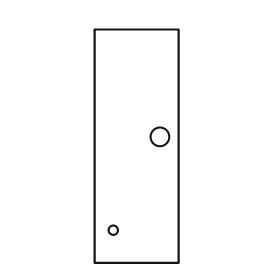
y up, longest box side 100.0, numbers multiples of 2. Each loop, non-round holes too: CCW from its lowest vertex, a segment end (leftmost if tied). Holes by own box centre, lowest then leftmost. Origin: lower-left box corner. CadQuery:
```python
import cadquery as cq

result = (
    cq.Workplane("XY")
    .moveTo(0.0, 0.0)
    .lineTo(36.0, 0.0)
    .lineTo(36.0, 100.0)
    .lineTo(0.0, 100.0)
    .close()
    .moveTo(8.0, 14.0)
    .circle(2.0)
    .moveTo(28.0, 54.0)
    .circle(4.0)
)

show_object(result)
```